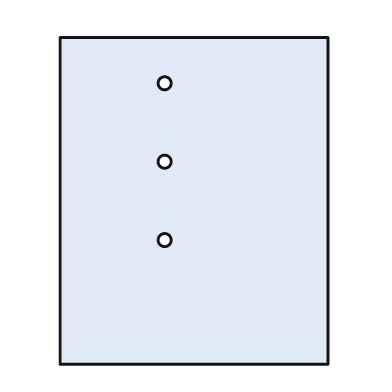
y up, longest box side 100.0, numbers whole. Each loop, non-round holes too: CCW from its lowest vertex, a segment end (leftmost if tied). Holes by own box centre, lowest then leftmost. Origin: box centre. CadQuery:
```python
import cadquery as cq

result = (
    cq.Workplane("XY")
    .moveTo(-41.0, -50.0)
    .lineTo(41.0, -50.0)
    .lineTo(41.0, 50.0)
    .lineTo(-41.0, 50.0)
    .close()
    .moveTo(-9.0, -12.0)
    .circle(2.0)
    .moveTo(-9.0, 12.0)
    .circle(2.0)
    .moveTo(-9.0, 36.0)
    .circle(2.0)
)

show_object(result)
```